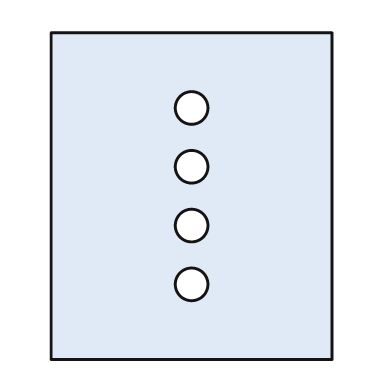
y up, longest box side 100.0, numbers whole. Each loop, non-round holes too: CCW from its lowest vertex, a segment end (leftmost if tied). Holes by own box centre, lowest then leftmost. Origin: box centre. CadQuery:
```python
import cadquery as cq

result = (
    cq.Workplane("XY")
    .moveTo(-43.0, -50.0)
    .lineTo(43.0, -50.0)
    .lineTo(43.0, 50.0)
    .lineTo(-43.0, 50.0)
    .close()
    .moveTo(0.0, -27.0)
    .circle(5.0)
    .moveTo(0.0, -9.0)
    .circle(5.0)
    .moveTo(0.0, 9.0)
    .circle(5.0)
    .moveTo(0.0, 27.0)
    .circle(5.0)
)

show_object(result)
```